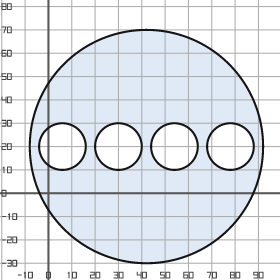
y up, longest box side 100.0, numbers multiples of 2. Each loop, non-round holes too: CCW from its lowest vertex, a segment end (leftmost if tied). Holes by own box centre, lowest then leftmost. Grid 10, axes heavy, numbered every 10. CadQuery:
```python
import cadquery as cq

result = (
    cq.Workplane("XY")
    .moveTo(42.0, 20.0)
    .circle(50.0)
    .moveTo(6.0, 20.0)
    .circle(10.0)
    .moveTo(30.0, 20.0)
    .circle(10.0)
    .moveTo(54.0, 20.0)
    .circle(10.0)
    .moveTo(78.0, 20.0)
    .circle(10.0)
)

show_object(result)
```